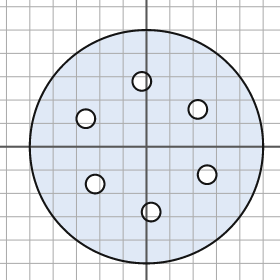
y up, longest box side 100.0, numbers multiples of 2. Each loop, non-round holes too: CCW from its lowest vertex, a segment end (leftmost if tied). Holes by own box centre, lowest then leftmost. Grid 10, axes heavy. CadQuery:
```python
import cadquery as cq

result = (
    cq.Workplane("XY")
    .moveTo(0.0, 0.0)
    .circle(50.0)
    .moveTo(2.0, -28.0)
    .circle(4.0)
    .moveTo(-22.0, -16.0)
    .circle(4.0)
    .moveTo(26.0, -12.0)
    .circle(4.0)
    .moveTo(-26.0, 12.0)
    .circle(4.0)
    .moveTo(22.0, 16.0)
    .circle(4.0)
    .moveTo(-2.0, 28.0)
    .circle(4.0)
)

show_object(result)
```